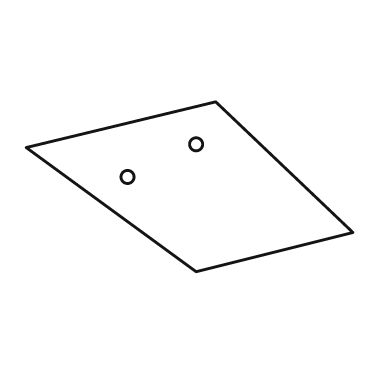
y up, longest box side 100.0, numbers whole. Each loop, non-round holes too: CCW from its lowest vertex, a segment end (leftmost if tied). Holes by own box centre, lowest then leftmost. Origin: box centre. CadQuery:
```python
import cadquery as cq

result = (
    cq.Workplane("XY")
    .moveTo(2.0, -26.0)
    .lineTo(50.0, -14.0)
    .lineTo(8.0, 26.0)
    .lineTo(-50.0, 12.0)
    .close()
    .moveTo(-19.0, 3.0)
    .circle(2.0)
    .moveTo(2.0, 13.0)
    .circle(2.0)
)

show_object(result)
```